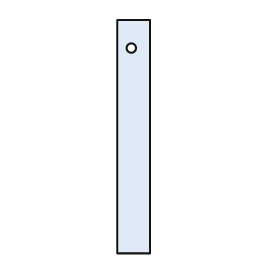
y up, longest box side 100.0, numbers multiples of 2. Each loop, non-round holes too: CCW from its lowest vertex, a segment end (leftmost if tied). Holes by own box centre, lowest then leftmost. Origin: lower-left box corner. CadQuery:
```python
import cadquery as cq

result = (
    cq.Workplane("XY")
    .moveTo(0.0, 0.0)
    .lineTo(14.0, 0.0)
    .lineTo(14.0, 100.0)
    .lineTo(0.0, 100.0)
    .close()
    .moveTo(6.0, 88.0)
    .circle(2.0)
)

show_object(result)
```